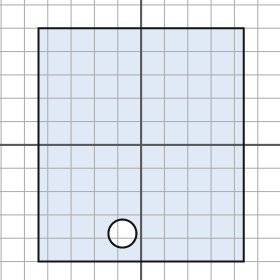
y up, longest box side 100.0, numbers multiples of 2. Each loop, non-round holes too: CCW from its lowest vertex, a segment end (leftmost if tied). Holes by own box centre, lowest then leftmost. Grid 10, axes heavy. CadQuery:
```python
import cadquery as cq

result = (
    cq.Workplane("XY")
    .moveTo(-44.0, -50.0)
    .lineTo(44.0, -50.0)
    .lineTo(44.0, 50.0)
    .lineTo(-44.0, 50.0)
    .close()
    .moveTo(-8.0, -38.0)
    .circle(6.0)
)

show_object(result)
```